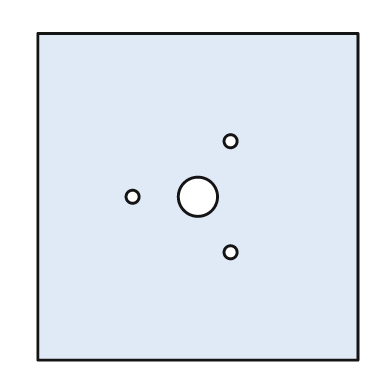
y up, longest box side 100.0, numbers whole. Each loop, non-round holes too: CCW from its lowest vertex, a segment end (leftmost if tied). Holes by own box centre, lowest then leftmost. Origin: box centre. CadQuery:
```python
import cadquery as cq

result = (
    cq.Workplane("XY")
    .moveTo(-49.0, -50.0)
    .lineTo(49.0, -50.0)
    .lineTo(49.0, 50.0)
    .lineTo(-49.0, 50.0)
    .close()
    .moveTo(10.0, -17.0)
    .circle(2.0)
    .moveTo(-20.0, 0.0)
    .circle(2.0)
    .moveTo(0.0, 0.0)
    .circle(6.0)
    .moveTo(10.0, 17.0)
    .circle(2.0)
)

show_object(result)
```